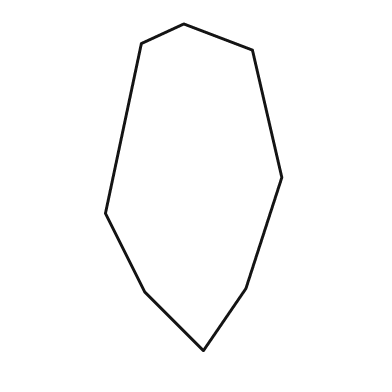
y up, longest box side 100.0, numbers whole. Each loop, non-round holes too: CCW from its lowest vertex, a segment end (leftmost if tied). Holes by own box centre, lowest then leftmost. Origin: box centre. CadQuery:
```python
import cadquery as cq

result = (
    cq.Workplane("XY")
    .moveTo(3.0, -50.0)
    .lineTo(16.0, -31.0)
    .lineTo(27.0, 3.0)
    .lineTo(18.0, 42.0)
    .lineTo(-3.0, 50.0)
    .lineTo(-16.0, 44.0)
    .lineTo(-27.0, -8.0)
    .lineTo(-15.0, -32.0)
    .close()
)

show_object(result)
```